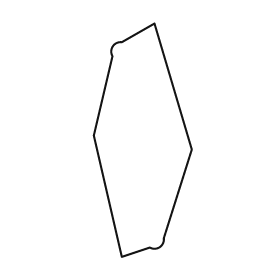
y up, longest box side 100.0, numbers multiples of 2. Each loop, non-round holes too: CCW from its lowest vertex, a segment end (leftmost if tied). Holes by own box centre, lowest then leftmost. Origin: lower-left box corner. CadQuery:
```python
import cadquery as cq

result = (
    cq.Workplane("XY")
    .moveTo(12.0, 0.0)
    .lineTo(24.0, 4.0)
    .threePointArc((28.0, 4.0), (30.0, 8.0))
    .lineTo(42.0, 46.0)
    .lineTo(26.0, 100.0)
    .lineTo(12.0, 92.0)
    .threePointArc((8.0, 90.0), (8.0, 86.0))
    .lineTo(0.0, 52.0)
    .close()
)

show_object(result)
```